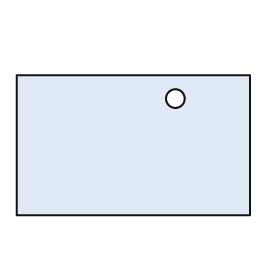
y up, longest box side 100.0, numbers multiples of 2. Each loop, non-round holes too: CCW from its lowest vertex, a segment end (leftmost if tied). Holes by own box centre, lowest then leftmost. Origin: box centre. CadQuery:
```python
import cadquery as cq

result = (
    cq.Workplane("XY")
    .moveTo(-50.0, -30.0)
    .lineTo(50.0, -30.0)
    .lineTo(50.0, 30.0)
    .lineTo(-50.0, 30.0)
    .close()
    .moveTo(18.0, 20.0)
    .circle(4.0)
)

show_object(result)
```